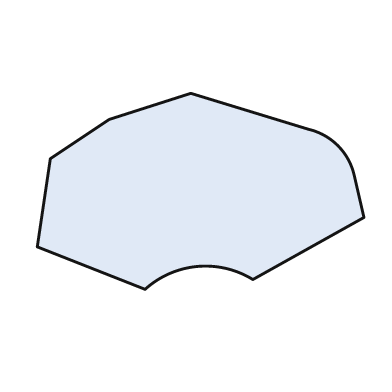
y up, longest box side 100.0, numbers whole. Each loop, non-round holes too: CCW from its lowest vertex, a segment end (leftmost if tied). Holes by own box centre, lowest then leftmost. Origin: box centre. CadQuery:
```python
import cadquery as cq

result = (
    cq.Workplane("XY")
    .moveTo(-17.0, -30.0)
    .threePointArc((-1.0, -23.0), (16.0, -27.0))
    .lineTo(50.0, -8.0)
    .lineTo(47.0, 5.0)
    .threePointArc((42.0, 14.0), (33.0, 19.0))
    .lineTo(-3.0, 30.0)
    .lineTo(-28.0, 22.0)
    .lineTo(-46.0, 10.0)
    .lineTo(-50.0, -17.0)
    .close()
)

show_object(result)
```